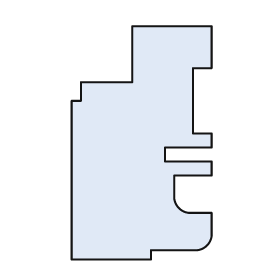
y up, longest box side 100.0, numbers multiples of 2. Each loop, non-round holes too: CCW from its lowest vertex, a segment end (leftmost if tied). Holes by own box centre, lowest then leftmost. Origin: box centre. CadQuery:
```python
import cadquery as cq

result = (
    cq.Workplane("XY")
    .moveTo(-30.0, -50.0)
    .lineTo(4.0, -50.0)
    .lineTo(4.0, -46.0)
    .lineTo(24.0, -46.0)
    .threePointArc((28.0, -44.0), (30.0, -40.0))
    .lineTo(30.0, -30.0)
    .lineTo(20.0, -30.0)
    .threePointArc((16.0, -28.0), (14.0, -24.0))
    .lineTo(14.0, -14.0)
    .lineTo(30.0, -14.0)
    .lineTo(30.0, -8.0)
    .lineTo(10.0, -8.0)
    .lineTo(10.0, -2.0)
    .lineTo(30.0, -2.0)
    .lineTo(30.0, 4.0)
    .lineTo(22.0, 4.0)
    .lineTo(22.0, 32.0)
    .lineTo(30.0, 32.0)
    .lineTo(30.0, 50.0)
    .lineTo(-4.0, 50.0)
    .lineTo(-4.0, 26.0)
    .lineTo(-26.0, 26.0)
    .lineTo(-26.0, 18.0)
    .lineTo(-30.0, 18.0)
    .close()
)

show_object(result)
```